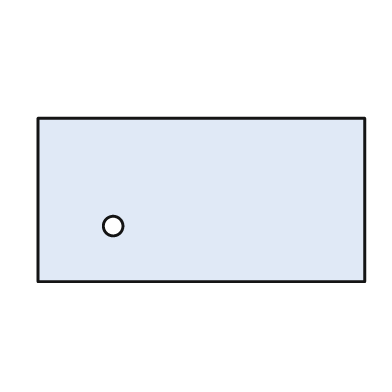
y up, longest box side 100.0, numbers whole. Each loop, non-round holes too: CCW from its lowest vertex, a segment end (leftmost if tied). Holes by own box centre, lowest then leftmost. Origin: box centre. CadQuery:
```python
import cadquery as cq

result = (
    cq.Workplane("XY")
    .moveTo(-50.0, -25.0)
    .lineTo(50.0, -25.0)
    .lineTo(50.0, 25.0)
    .lineTo(-50.0, 25.0)
    .close()
    .moveTo(-27.0, -8.0)
    .circle(3.0)
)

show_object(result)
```